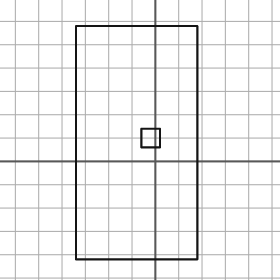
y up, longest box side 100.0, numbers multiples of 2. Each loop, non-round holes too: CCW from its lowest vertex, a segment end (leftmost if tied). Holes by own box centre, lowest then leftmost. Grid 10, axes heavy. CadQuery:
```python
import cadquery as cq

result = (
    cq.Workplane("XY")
    .moveTo(-34.0, -42.0)
    .lineTo(18.0, -42.0)
    .lineTo(18.0, 58.0)
    .lineTo(-34.0, 58.0)
    .close()
    .moveTo(-6.0, 6.0)
    .lineTo(2.0, 6.0)
    .lineTo(2.0, 14.0)
    .lineTo(-6.0, 14.0)
    .close()
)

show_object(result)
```